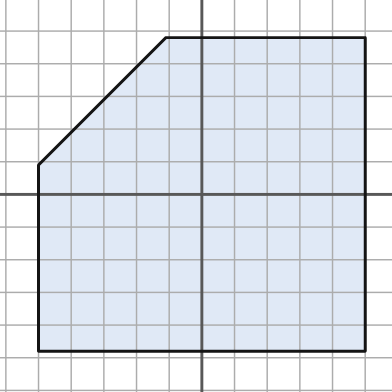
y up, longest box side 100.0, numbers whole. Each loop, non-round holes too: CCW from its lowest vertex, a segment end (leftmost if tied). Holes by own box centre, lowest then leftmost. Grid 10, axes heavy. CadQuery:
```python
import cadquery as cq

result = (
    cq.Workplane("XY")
    .moveTo(-50.0, -48.0)
    .lineTo(50.0, -48.0)
    .lineTo(50.0, 48.0)
    .lineTo(-11.0, 48.0)
    .lineTo(-50.0, 9.0)
    .close()
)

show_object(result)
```